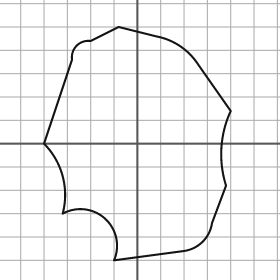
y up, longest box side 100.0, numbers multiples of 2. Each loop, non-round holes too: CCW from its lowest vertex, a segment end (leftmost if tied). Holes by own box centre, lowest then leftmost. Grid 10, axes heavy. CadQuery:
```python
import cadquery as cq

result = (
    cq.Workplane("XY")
    .moveTo(-10.0, -50.0)
    .lineTo(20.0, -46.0)
    .threePointArc((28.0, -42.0), (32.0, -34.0))
    .lineTo(38.0, -18.0)
    .threePointArc((36.0, -2.0), (40.0, 14.0))
    .lineTo(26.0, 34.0)
    .threePointArc((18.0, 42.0), (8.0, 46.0))
    .lineTo(-8.0, 50.0)
    .lineTo(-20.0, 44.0)
    .threePointArc((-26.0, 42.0), (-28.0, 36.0))
    .lineTo(-40.0, 0.0)
    .threePointArc((-32.0, -14.0), (-32.0, -30.0))
    .threePointArc((-14.0, -32.0), (-10.0, -50.0))
    .close()
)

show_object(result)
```